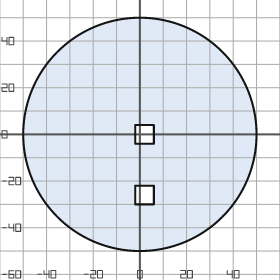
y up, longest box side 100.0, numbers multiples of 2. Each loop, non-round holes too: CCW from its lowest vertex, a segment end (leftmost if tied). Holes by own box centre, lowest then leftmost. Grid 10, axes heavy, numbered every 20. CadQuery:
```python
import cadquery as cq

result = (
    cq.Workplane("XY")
    .moveTo(0.0, 0.0)
    .circle(50.0)
    .moveTo(-2.0, -30.0)
    .lineTo(6.0, -30.0)
    .lineTo(6.0, -22.0)
    .lineTo(-2.0, -22.0)
    .close()
    .moveTo(-2.0, -4.0)
    .lineTo(6.0, -4.0)
    .lineTo(6.0, 4.0)
    .lineTo(-2.0, 4.0)
    .close()
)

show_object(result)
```